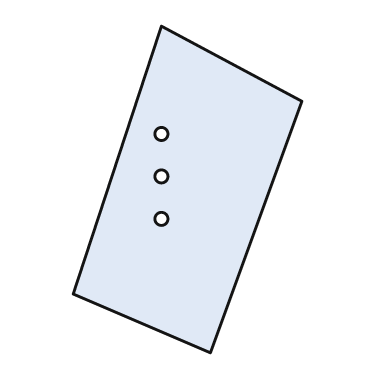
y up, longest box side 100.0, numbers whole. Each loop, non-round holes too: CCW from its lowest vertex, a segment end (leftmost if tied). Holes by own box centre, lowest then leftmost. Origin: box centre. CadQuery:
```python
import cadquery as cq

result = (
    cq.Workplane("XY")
    .moveTo(7.0, -50.0)
    .lineTo(35.0, 27.0)
    .lineTo(-8.0, 50.0)
    .lineTo(-35.0, -32.0)
    .close()
    .moveTo(-8.0, -9.0)
    .circle(2.0)
    .moveTo(-8.0, 4.0)
    .circle(2.0)
    .moveTo(-8.0, 17.0)
    .circle(2.0)
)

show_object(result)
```